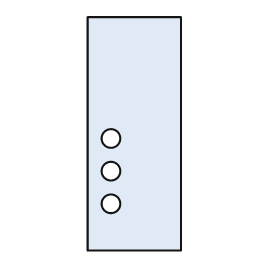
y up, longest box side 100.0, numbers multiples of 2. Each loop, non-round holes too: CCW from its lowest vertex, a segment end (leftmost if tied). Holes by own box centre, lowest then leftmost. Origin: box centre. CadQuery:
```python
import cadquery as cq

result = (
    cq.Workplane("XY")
    .moveTo(-20.0, -50.0)
    .lineTo(20.0, -50.0)
    .lineTo(20.0, 50.0)
    .lineTo(-20.0, 50.0)
    .close()
    .moveTo(-10.0, -30.0)
    .circle(4.0)
    .moveTo(-10.0, -16.0)
    .circle(4.0)
    .moveTo(-10.0, -2.0)
    .circle(4.0)
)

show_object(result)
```